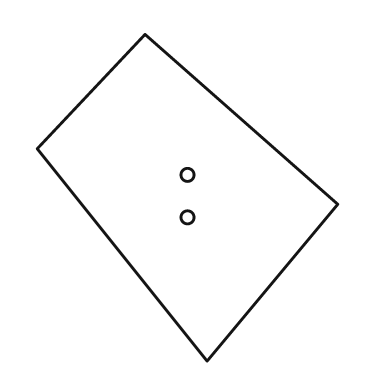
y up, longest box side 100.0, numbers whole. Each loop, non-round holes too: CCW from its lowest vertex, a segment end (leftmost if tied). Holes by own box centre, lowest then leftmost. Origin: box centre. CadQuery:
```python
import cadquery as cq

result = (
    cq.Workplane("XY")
    .moveTo(6.0, -50.0)
    .lineTo(46.0, -2.0)
    .lineTo(-13.0, 50.0)
    .lineTo(-46.0, 15.0)
    .close()
    .moveTo(0.0, -6.0)
    .circle(2.0)
    .moveTo(0.0, 7.0)
    .circle(2.0)
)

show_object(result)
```